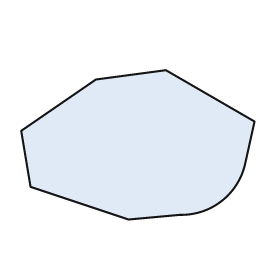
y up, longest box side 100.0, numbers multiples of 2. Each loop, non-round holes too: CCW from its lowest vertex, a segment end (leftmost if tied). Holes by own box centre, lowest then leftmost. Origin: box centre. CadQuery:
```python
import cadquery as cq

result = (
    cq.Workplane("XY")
    .moveTo(-4.0, -32.0)
    .lineTo(18.0, -30.0)
    .threePointArc((36.0, -24.0), (46.0, -8.0))
    .lineTo(50.0, 10.0)
    .lineTo(12.0, 32.0)
    .lineTo(-18.0, 28.0)
    .lineTo(-50.0, 6.0)
    .lineTo(-46.0, -18.0)
    .close()
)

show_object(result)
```